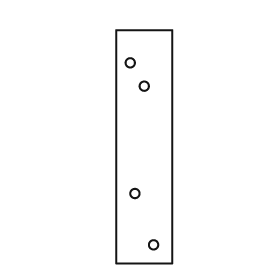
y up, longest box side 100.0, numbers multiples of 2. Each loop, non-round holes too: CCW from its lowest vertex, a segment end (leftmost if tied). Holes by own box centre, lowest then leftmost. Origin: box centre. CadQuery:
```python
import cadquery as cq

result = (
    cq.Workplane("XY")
    .moveTo(-12.0, -50.0)
    .lineTo(12.0, -50.0)
    .lineTo(12.0, 50.0)
    .lineTo(-12.0, 50.0)
    .close()
    .moveTo(4.0, -42.0)
    .circle(2.0)
    .moveTo(-4.0, -20.0)
    .circle(2.0)
    .moveTo(0.0, 26.0)
    .circle(2.0)
    .moveTo(-6.0, 36.0)
    .circle(2.0)
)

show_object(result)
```